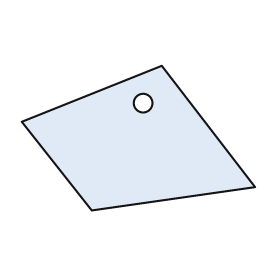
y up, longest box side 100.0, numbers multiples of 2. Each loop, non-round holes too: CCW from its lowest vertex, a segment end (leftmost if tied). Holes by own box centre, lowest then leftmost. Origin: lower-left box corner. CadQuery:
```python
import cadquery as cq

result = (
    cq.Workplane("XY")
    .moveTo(30.0, 0.0)
    .lineTo(100.0, 10.0)
    .lineTo(60.0, 62.0)
    .lineTo(0.0, 38.0)
    .close()
    .moveTo(52.0, 46.0)
    .circle(4.0)
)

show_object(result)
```